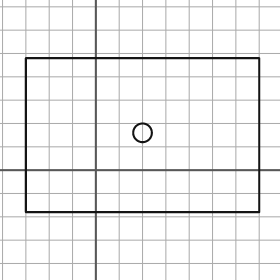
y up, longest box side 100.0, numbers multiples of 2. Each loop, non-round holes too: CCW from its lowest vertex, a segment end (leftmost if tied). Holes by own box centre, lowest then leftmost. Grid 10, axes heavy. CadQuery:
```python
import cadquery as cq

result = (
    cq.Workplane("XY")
    .moveTo(-30.0, -18.0)
    .lineTo(70.0, -18.0)
    .lineTo(70.0, 48.0)
    .lineTo(-30.0, 48.0)
    .close()
    .moveTo(20.0, 16.0)
    .circle(4.0)
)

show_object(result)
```